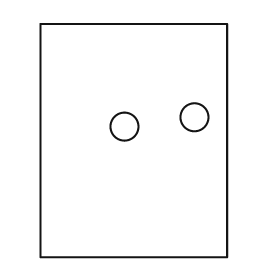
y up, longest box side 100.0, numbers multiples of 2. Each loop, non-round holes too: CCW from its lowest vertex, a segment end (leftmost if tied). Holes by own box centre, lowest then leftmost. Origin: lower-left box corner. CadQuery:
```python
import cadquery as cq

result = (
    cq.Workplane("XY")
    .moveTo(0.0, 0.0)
    .lineTo(80.0, 0.0)
    .lineTo(80.0, 100.0)
    .lineTo(0.0, 100.0)
    .close()
    .moveTo(36.0, 56.0)
    .circle(6.0)
    .moveTo(66.0, 60.0)
    .circle(6.0)
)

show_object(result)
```